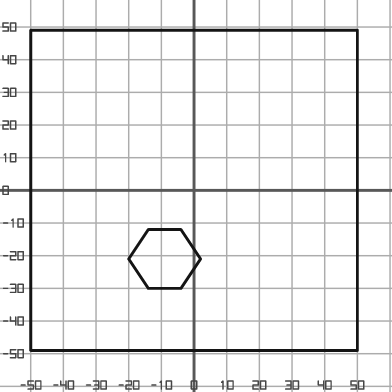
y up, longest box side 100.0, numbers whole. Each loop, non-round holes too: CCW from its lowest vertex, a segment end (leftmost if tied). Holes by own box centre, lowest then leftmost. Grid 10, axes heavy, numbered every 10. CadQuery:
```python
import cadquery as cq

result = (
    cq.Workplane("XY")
    .moveTo(-50.0, -49.0)
    .lineTo(50.0, -49.0)
    .lineTo(50.0, 49.0)
    .lineTo(-50.0, 49.0)
    .close()
    .moveTo(-14.0, -30.0)
    .lineTo(-4.0, -30.0)
    .lineTo(2.0, -21.0)
    .lineTo(-4.0, -12.0)
    .lineTo(-14.0, -12.0)
    .lineTo(-20.0, -21.0)
    .close()
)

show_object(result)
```